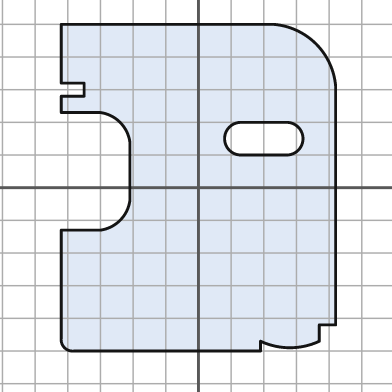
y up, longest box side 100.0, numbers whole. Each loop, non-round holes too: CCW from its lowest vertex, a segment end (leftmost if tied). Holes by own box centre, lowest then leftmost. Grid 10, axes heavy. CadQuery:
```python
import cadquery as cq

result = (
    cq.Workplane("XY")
    .moveTo(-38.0, -50.0)
    .lineTo(19.0, -50.0)
    .lineTo(19.0, -47.0)
    .threePointArc((28.0, -49.0), (37.0, -47.0))
    .lineTo(37.0, -42.0)
    .lineTo(42.0, -42.0)
    .lineTo(42.0, 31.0)
    .threePointArc((36.0, 44.0), (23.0, 50.0))
    .lineTo(-42.0, 50.0)
    .lineTo(-42.0, 32.0)
    .lineTo(-35.0, 32.0)
    .lineTo(-35.0, 28.0)
    .lineTo(-42.0, 28.0)
    .lineTo(-42.0, 23.0)
    .lineTo(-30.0, 23.0)
    .threePointArc((-24.0, 20.0), (-21.0, 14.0))
    .lineTo(-21.0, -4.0)
    .threePointArc((-24.0, -10.0), (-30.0, -13.0))
    .lineTo(-42.0, -13.0)
    .lineTo(-42.0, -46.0)
    .threePointArc((-41.0, -49.0), (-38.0, -50.0))
    .close()
    .moveTo(13.0, 10.0)
    .lineTo(27.0, 10.0)
    .threePointArc((32.0, 15.0), (27.0, 20.0))
    .lineTo(13.0, 20.0)
    .threePointArc((8.0, 15.0), (13.0, 10.0))
    .close()
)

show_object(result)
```